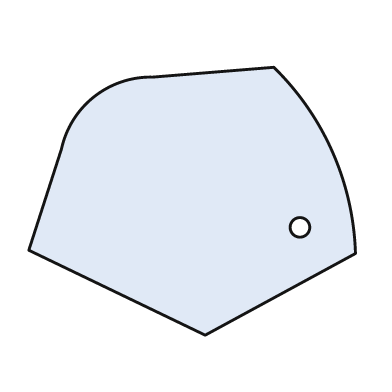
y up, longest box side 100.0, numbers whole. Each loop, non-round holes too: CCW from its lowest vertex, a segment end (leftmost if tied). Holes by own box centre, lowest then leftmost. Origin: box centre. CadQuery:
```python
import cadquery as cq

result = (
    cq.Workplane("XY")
    .moveTo(4.0, -41.0)
    .lineTo(50.0, -16.0)
    .threePointArc((43.0, 15.0), (25.0, 41.0))
    .lineTo(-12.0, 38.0)
    .threePointArc((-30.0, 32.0), (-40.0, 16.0))
    .lineTo(-50.0, -15.0)
    .close()
    .moveTo(33.0, -8.0)
    .circle(3.0)
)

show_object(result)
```